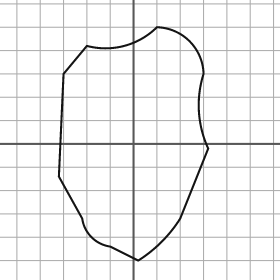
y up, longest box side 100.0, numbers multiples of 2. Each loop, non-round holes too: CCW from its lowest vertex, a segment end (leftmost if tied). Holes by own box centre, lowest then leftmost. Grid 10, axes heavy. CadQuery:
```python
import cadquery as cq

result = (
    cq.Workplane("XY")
    .moveTo(2.0, -50.0)
    .threePointArc((12.0, -42.0), (20.0, -32.0))
    .lineTo(32.0, -2.0)
    .threePointArc((28.0, 14.0), (30.0, 30.0))
    .threePointArc((24.0, 44.0), (10.0, 50.0))
    .threePointArc((-4.0, 42.0), (-20.0, 42.0))
    .lineTo(-30.0, 30.0)
    .lineTo(-32.0, -14.0)
    .lineTo(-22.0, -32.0)
    .threePointArc((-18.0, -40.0), (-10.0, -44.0))
    .close()
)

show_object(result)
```